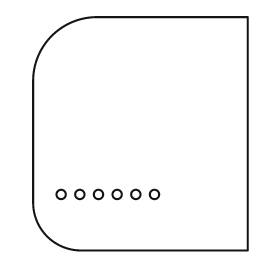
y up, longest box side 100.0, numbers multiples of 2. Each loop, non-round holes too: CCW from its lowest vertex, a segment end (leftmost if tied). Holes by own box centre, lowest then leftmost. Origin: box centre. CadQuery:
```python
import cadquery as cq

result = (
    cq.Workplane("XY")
    .moveTo(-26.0, -50.0)
    .lineTo(46.0, -50.0)
    .lineTo(46.0, 50.0)
    .lineTo(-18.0, 50.0)
    .threePointArc((-38.0, 42.0), (-46.0, 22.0))
    .lineTo(-46.0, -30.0)
    .threePointArc((-40.0, -44.0), (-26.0, -50.0))
    .close()
    .moveTo(-34.0, -26.0)
    .circle(2.0)
    .moveTo(-26.0, -26.0)
    .circle(2.0)
    .moveTo(-18.0, -26.0)
    .circle(2.0)
    .moveTo(-10.0, -26.0)
    .circle(2.0)
    .moveTo(-2.0, -26.0)
    .circle(2.0)
    .moveTo(6.0, -26.0)
    .circle(2.0)
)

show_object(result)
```